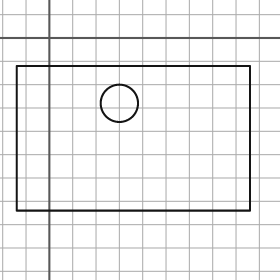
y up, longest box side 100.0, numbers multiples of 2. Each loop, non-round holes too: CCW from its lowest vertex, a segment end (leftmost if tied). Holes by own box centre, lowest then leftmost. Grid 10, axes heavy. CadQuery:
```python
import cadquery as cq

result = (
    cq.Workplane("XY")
    .moveTo(-14.0, -74.0)
    .lineTo(86.0, -74.0)
    .lineTo(86.0, -12.0)
    .lineTo(-14.0, -12.0)
    .close()
    .moveTo(30.0, -28.0)
    .circle(8.0)
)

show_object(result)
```